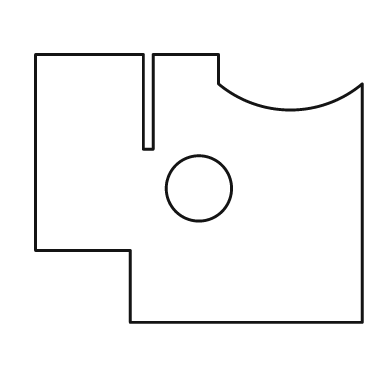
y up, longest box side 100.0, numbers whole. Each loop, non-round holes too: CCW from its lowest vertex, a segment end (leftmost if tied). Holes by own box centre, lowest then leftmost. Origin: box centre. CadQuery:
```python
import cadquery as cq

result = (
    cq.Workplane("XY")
    .moveTo(-21.0, -41.0)
    .lineTo(50.0, -41.0)
    .lineTo(50.0, 32.0)
    .threePointArc((28.0, 24.0), (6.0, 32.0))
    .lineTo(6.0, 41.0)
    .lineTo(-14.0, 41.0)
    .lineTo(-14.0, 12.0)
    .lineTo(-17.0, 12.0)
    .lineTo(-17.0, 41.0)
    .lineTo(-50.0, 41.0)
    .lineTo(-50.0, -19.0)
    .lineTo(-21.0, -19.0)
    .close()
    .moveTo(0.0, 0.0)
    .circle(10.0)
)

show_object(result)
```